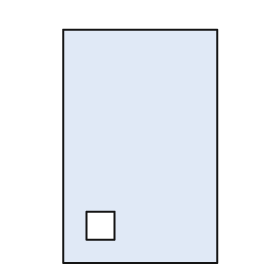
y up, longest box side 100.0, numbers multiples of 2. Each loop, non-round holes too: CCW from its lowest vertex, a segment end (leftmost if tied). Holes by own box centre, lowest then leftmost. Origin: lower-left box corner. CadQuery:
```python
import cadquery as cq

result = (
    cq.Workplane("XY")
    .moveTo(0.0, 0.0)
    .lineTo(66.0, 0.0)
    .lineTo(66.0, 100.0)
    .lineTo(0.0, 100.0)
    .close()
    .moveTo(10.0, 10.0)
    .lineTo(22.0, 10.0)
    .lineTo(22.0, 22.0)
    .lineTo(10.0, 22.0)
    .close()
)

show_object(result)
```